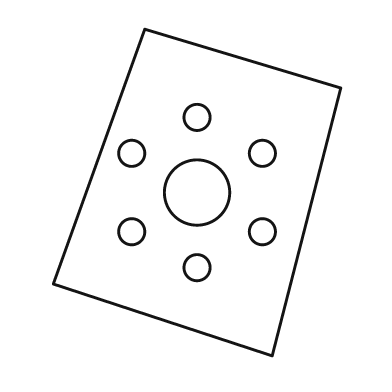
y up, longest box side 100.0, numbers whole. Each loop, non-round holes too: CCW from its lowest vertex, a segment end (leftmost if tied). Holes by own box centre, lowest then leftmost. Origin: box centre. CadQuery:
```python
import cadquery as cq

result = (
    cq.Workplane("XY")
    .moveTo(23.0, -50.0)
    .lineTo(44.0, 32.0)
    .lineTo(-16.0, 50.0)
    .lineTo(-44.0, -28.0)
    .close()
    .moveTo(0.0, -23.0)
    .circle(4.0)
    .moveTo(-20.0, -12.0)
    .circle(4.0)
    .moveTo(20.0, -12.0)
    .circle(4.0)
    .moveTo(0.0, 0.0)
    .circle(10.0)
    .moveTo(-20.0, 12.0)
    .circle(4.0)
    .moveTo(20.0, 12.0)
    .circle(4.0)
    .moveTo(0.0, 23.0)
    .circle(4.0)
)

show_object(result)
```